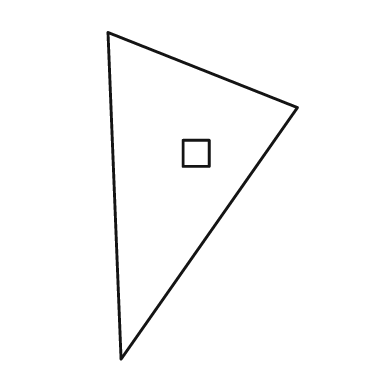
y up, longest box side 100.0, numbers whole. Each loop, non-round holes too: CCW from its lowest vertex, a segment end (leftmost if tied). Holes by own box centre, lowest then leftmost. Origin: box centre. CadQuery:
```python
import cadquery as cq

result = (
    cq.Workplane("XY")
    .moveTo(-25.0, -50.0)
    .lineTo(29.0, 27.0)
    .lineTo(-29.0, 50.0)
    .close()
    .moveTo(-6.0, 9.0)
    .lineTo(2.0, 9.0)
    .lineTo(2.0, 17.0)
    .lineTo(-6.0, 17.0)
    .close()
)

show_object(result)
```